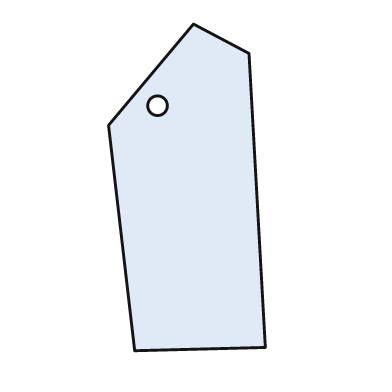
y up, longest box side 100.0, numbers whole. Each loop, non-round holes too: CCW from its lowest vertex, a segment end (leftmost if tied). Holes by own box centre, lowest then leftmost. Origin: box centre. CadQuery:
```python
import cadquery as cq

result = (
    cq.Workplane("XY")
    .moveTo(-16.0, -50.0)
    .lineTo(24.0, -49.0)
    .lineTo(19.0, 41.0)
    .lineTo(2.0, 50.0)
    .lineTo(-24.0, 19.0)
    .close()
    .moveTo(-9.0, 25.0)
    .circle(3.0)
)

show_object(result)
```